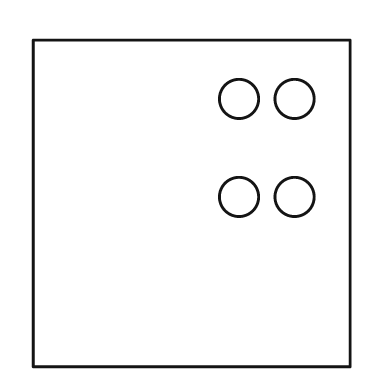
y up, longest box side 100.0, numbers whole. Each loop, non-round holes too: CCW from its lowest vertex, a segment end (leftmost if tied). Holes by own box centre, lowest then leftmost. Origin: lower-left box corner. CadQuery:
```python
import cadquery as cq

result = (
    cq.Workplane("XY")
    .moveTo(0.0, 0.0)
    .lineTo(97.0, 0.0)
    .lineTo(97.0, 100.0)
    .lineTo(0.0, 100.0)
    .close()
    .moveTo(63.0, 52.0)
    .circle(6.0)
    .moveTo(80.0, 52.0)
    .circle(6.0)
    .moveTo(63.0, 82.0)
    .circle(6.0)
    .moveTo(80.0, 82.0)
    .circle(6.0)
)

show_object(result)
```